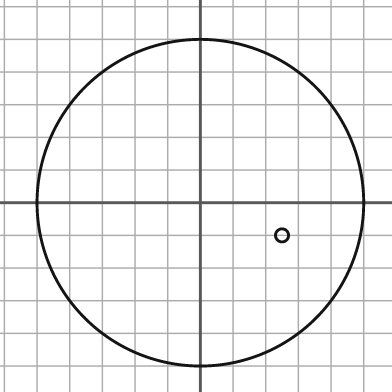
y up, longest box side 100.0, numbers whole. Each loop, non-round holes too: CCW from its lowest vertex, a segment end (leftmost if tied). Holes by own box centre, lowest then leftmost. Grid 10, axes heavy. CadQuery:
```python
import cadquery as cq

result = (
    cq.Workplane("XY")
    .moveTo(0.0, 0.0)
    .circle(50.0)
    .moveTo(25.0, -10.0)
    .circle(2.0)
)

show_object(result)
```